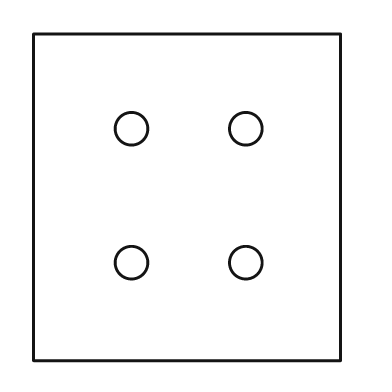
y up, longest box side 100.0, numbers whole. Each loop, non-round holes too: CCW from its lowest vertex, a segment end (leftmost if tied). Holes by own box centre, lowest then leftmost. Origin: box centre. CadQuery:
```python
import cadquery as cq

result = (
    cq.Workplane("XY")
    .moveTo(-47.0, -50.0)
    .lineTo(47.0, -50.0)
    .lineTo(47.0, 50.0)
    .lineTo(-47.0, 50.0)
    .close()
    .moveTo(-17.0, -20.0)
    .circle(5.0)
    .moveTo(18.0, -20.0)
    .circle(5.0)
    .moveTo(-17.0, 21.0)
    .circle(5.0)
    .moveTo(18.0, 21.0)
    .circle(5.0)
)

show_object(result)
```